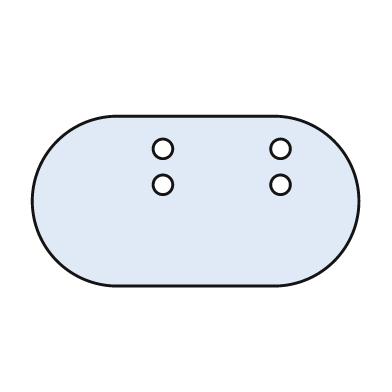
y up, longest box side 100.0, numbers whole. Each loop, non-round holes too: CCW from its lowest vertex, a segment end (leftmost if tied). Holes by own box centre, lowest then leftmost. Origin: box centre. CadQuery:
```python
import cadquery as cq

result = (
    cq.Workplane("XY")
    .moveTo(-24.0, -26.0)
    .lineTo(24.0, -26.0)
    .threePointArc((50.0, 0.0), (24.0, 26.0))
    .lineTo(-24.0, 26.0)
    .threePointArc((-50.0, 0.0), (-24.0, -26.0))
    .close()
    .moveTo(-10.0, 5.0)
    .circle(3.0)
    .moveTo(26.0, 5.0)
    .circle(3.0)
    .moveTo(-10.0, 16.0)
    .circle(3.0)
    .moveTo(26.0, 16.0)
    .circle(3.0)
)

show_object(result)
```